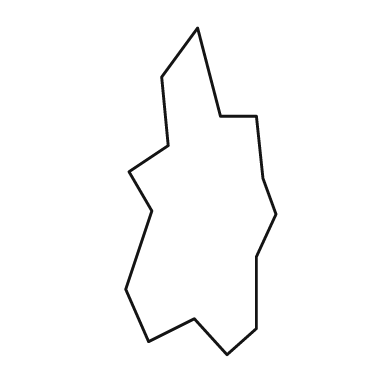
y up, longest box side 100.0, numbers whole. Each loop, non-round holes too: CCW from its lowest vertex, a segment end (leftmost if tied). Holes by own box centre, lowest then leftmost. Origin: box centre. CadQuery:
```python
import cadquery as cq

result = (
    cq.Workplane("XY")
    .moveTo(8.0, -50.0)
    .lineTo(17.0, -42.0)
    .lineTo(17.0, -20.0)
    .lineTo(23.0, -7.0)
    .lineTo(19.0, 4.0)
    .lineTo(17.0, 23.0)
    .lineTo(6.0, 23.0)
    .lineTo(-1.0, 50.0)
    .lineTo(-12.0, 35.0)
    .lineTo(-10.0, 14.0)
    .lineTo(-22.0, 6.0)
    .lineTo(-15.0, -6.0)
    .lineTo(-23.0, -30.0)
    .lineTo(-16.0, -46.0)
    .lineTo(-2.0, -39.0)
    .close()
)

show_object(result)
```